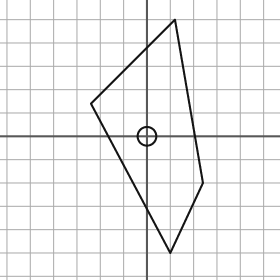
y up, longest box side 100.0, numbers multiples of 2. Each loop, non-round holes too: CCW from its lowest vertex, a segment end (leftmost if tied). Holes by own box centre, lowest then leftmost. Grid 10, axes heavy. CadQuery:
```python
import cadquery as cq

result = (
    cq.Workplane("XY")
    .moveTo(10.0, -50.0)
    .lineTo(24.0, -20.0)
    .lineTo(12.0, 50.0)
    .lineTo(-24.0, 14.0)
    .close()
    .moveTo(0.0, 0.0)
    .circle(4.0)
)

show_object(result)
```